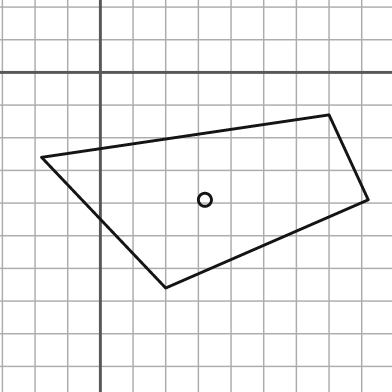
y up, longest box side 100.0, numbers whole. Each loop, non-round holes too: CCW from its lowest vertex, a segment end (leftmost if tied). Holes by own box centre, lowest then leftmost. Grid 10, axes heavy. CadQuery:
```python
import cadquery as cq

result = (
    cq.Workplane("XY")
    .moveTo(20.0, -66.0)
    .lineTo(82.0, -39.0)
    .lineTo(70.0, -13.0)
    .lineTo(-18.0, -26.0)
    .close()
    .moveTo(32.0, -39.0)
    .circle(2.0)
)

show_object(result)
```